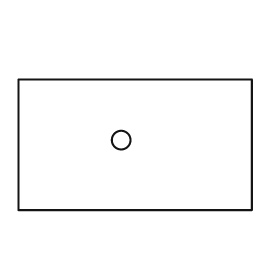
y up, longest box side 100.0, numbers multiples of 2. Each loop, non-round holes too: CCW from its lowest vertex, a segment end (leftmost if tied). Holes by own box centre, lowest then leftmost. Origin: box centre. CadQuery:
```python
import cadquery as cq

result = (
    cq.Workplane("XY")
    .moveTo(-50.0, -28.0)
    .lineTo(50.0, -28.0)
    .lineTo(50.0, 28.0)
    .lineTo(-50.0, 28.0)
    .close()
    .moveTo(-6.0, 2.0)
    .circle(4.0)
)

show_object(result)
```